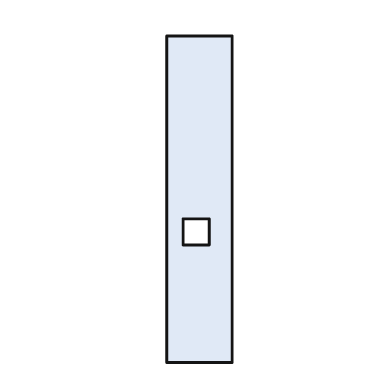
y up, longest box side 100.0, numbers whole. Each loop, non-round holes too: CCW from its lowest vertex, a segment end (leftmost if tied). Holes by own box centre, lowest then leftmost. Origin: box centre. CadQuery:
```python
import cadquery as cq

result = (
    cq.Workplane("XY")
    .moveTo(-10.0, -50.0)
    .lineTo(10.0, -50.0)
    .lineTo(10.0, 50.0)
    .lineTo(-10.0, 50.0)
    .close()
    .moveTo(-5.0, -14.0)
    .lineTo(3.0, -14.0)
    .lineTo(3.0, -6.0)
    .lineTo(-5.0, -6.0)
    .close()
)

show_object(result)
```